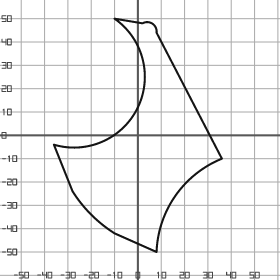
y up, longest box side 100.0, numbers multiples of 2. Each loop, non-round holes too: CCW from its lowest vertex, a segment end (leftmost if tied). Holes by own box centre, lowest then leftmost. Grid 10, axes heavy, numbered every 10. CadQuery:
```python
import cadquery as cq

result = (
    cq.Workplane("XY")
    .moveTo(8.0, -50.0)
    .threePointArc((16.0, -26.0), (36.0, -10.0))
    .lineTo(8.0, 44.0)
    .threePointArc((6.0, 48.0), (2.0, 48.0))
    .lineTo(-10.0, 50.0)
    .threePointArc((0.0, 12.0), (-36.0, -4.0))
    .lineTo(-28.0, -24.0)
    .threePointArc((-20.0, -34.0), (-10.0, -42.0))
    .close()
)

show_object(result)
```